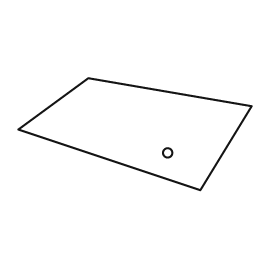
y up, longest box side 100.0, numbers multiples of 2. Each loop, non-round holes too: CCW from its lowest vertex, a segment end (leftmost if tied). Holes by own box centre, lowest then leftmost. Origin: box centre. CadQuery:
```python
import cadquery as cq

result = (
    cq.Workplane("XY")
    .moveTo(28.0, -24.0)
    .lineTo(50.0, 12.0)
    .lineTo(-20.0, 24.0)
    .lineTo(-50.0, 2.0)
    .close()
    .moveTo(14.0, -8.0)
    .circle(2.0)
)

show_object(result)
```